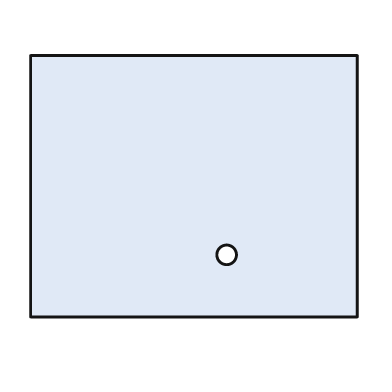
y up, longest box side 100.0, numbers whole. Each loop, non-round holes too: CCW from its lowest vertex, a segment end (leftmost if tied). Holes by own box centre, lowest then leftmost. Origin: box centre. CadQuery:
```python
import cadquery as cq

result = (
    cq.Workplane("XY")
    .moveTo(-50.0, -40.0)
    .lineTo(50.0, -40.0)
    .lineTo(50.0, 40.0)
    .lineTo(-50.0, 40.0)
    .close()
    .moveTo(10.0, -21.0)
    .circle(3.0)
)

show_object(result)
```